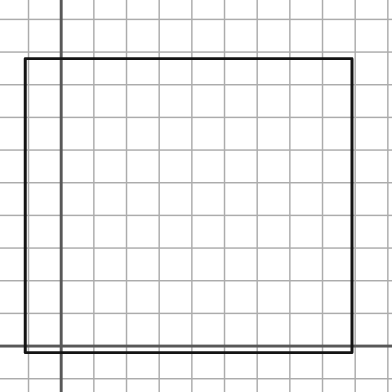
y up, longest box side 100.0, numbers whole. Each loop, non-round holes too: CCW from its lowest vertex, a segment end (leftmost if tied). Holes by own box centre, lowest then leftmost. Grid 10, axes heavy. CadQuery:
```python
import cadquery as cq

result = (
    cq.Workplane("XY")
    .moveTo(-11.0, -2.0)
    .lineTo(89.0, -2.0)
    .lineTo(89.0, 88.0)
    .lineTo(-11.0, 88.0)
    .close()
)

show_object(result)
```